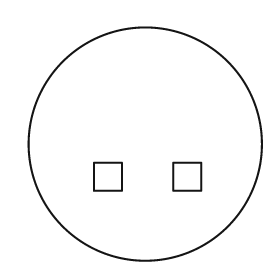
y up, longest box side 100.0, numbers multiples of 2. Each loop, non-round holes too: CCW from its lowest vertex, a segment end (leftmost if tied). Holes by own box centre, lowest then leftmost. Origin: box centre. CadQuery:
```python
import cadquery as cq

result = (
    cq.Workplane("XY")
    .moveTo(0.0, 0.0)
    .circle(50.0)
    .moveTo(-22.0, -20.0)
    .lineTo(-10.0, -20.0)
    .lineTo(-10.0, -8.0)
    .lineTo(-22.0, -8.0)
    .close()
    .moveTo(12.0, -20.0)
    .lineTo(24.0, -20.0)
    .lineTo(24.0, -8.0)
    .lineTo(12.0, -8.0)
    .close()
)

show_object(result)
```